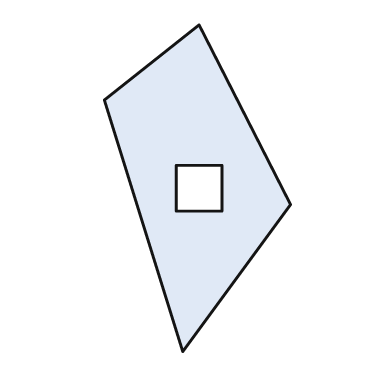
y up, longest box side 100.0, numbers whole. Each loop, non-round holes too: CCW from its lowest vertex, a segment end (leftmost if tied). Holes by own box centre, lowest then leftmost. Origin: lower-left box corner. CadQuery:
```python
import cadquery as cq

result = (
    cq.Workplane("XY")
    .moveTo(24.0, 0.0)
    .lineTo(57.0, 45.0)
    .lineTo(29.0, 100.0)
    .lineTo(0.0, 77.0)
    .close()
    .moveTo(22.0, 43.0)
    .lineTo(36.0, 43.0)
    .lineTo(36.0, 57.0)
    .lineTo(22.0, 57.0)
    .close()
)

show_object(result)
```